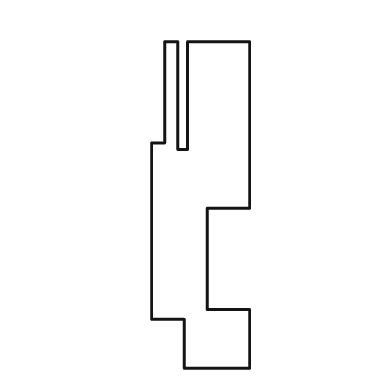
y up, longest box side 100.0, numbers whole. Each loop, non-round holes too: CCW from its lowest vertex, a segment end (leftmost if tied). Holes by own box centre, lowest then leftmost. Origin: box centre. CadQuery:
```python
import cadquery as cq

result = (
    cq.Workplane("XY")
    .moveTo(-5.0, -50.0)
    .lineTo(15.0, -50.0)
    .lineTo(15.0, -32.0)
    .lineTo(2.0, -32.0)
    .lineTo(2.0, -1.0)
    .lineTo(15.0, -1.0)
    .lineTo(15.0, 50.0)
    .lineTo(-4.0, 50.0)
    .lineTo(-4.0, 17.0)
    .lineTo(-7.0, 17.0)
    .lineTo(-7.0, 50.0)
    .lineTo(-11.0, 50.0)
    .lineTo(-11.0, 19.0)
    .lineTo(-15.0, 19.0)
    .lineTo(-15.0, -35.0)
    .lineTo(-5.0, -35.0)
    .close()
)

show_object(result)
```